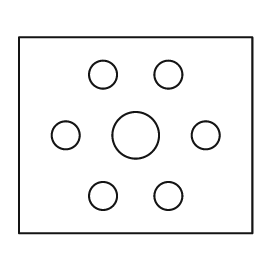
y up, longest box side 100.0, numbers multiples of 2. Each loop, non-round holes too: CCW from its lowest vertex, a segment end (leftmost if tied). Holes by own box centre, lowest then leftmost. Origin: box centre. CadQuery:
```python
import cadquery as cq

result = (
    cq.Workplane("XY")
    .moveTo(-50.0, -42.0)
    .lineTo(50.0, -42.0)
    .lineTo(50.0, 42.0)
    .lineTo(-50.0, 42.0)
    .close()
    .moveTo(-14.0, -26.0)
    .circle(6.0)
    .moveTo(14.0, -26.0)
    .circle(6.0)
    .moveTo(-30.0, 0.0)
    .circle(6.0)
    .moveTo(0.0, 0.0)
    .circle(10.0)
    .moveTo(30.0, 0.0)
    .circle(6.0)
    .moveTo(-14.0, 26.0)
    .circle(6.0)
    .moveTo(14.0, 26.0)
    .circle(6.0)
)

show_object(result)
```